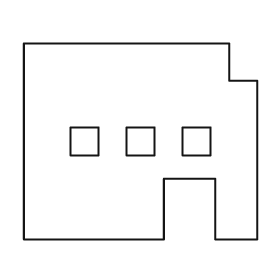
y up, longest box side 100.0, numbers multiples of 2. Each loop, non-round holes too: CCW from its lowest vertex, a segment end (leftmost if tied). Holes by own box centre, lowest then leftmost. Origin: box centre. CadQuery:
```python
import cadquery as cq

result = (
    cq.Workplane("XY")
    .moveTo(-50.0, -42.0)
    .lineTo(10.0, -42.0)
    .lineTo(10.0, -16.0)
    .lineTo(32.0, -16.0)
    .lineTo(32.0, -42.0)
    .lineTo(50.0, -42.0)
    .lineTo(50.0, 26.0)
    .lineTo(38.0, 26.0)
    .lineTo(38.0, 42.0)
    .lineTo(-50.0, 42.0)
    .close()
    .moveTo(-30.0, -6.0)
    .lineTo(-18.0, -6.0)
    .lineTo(-18.0, 6.0)
    .lineTo(-30.0, 6.0)
    .close()
    .moveTo(-6.0, -6.0)
    .lineTo(6.0, -6.0)
    .lineTo(6.0, 6.0)
    .lineTo(-6.0, 6.0)
    .close()
    .moveTo(18.0, -6.0)
    .lineTo(30.0, -6.0)
    .lineTo(30.0, 6.0)
    .lineTo(18.0, 6.0)
    .close()
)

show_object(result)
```